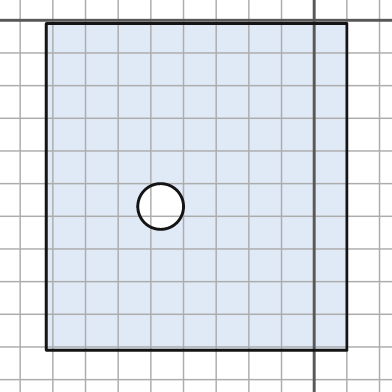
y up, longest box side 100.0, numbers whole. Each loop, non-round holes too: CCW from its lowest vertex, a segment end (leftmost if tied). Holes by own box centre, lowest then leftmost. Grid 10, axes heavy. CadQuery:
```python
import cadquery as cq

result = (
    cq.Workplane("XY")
    .moveTo(-82.0, -101.0)
    .lineTo(10.0, -101.0)
    .lineTo(10.0, -1.0)
    .lineTo(-82.0, -1.0)
    .close()
    .moveTo(-47.0, -57.0)
    .circle(7.0)
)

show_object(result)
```